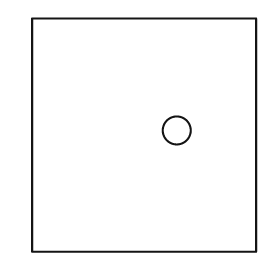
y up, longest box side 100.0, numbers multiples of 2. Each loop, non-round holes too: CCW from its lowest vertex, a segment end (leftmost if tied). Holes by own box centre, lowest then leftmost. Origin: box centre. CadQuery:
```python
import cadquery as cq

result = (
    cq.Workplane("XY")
    .moveTo(-48.0, -50.0)
    .lineTo(48.0, -50.0)
    .lineTo(48.0, 50.0)
    .lineTo(-48.0, 50.0)
    .close()
    .moveTo(14.0, 2.0)
    .circle(6.0)
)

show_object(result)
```